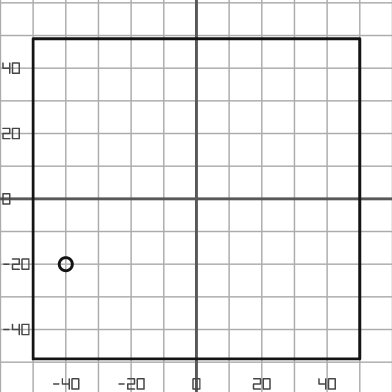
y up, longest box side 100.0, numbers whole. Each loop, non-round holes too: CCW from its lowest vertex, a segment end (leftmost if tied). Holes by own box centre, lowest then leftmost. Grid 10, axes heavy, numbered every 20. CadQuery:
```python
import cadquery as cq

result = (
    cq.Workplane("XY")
    .moveTo(-50.0, -49.0)
    .lineTo(50.0, -49.0)
    .lineTo(50.0, 49.0)
    .lineTo(-50.0, 49.0)
    .close()
    .moveTo(-40.0, -20.0)
    .circle(2.0)
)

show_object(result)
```